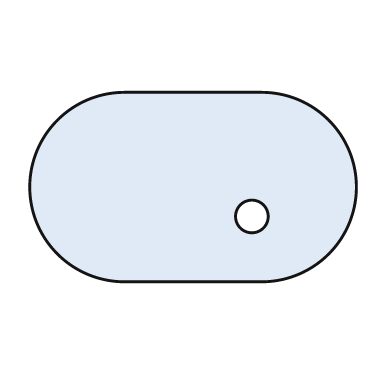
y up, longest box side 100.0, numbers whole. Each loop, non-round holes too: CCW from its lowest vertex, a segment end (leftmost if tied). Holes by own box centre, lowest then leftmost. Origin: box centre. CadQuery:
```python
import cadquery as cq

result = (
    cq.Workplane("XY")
    .moveTo(-21.0, -29.0)
    .lineTo(21.0, -29.0)
    .threePointArc((50.0, 0.0), (21.0, 29.0))
    .lineTo(-21.0, 29.0)
    .threePointArc((-50.0, 0.0), (-21.0, -29.0))
    .close()
    .moveTo(18.0, -9.0)
    .circle(5.0)
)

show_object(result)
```